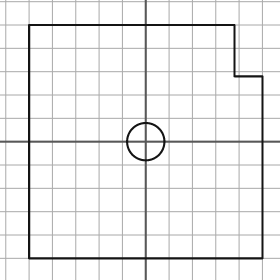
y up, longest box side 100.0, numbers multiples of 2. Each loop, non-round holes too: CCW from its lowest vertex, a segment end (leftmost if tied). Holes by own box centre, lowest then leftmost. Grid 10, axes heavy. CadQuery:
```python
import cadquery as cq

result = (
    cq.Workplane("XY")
    .moveTo(-50.0, -50.0)
    .lineTo(50.0, -50.0)
    .lineTo(50.0, 28.0)
    .lineTo(38.0, 28.0)
    .lineTo(38.0, 50.0)
    .lineTo(-50.0, 50.0)
    .close()
    .moveTo(0.0, 0.0)
    .circle(8.0)
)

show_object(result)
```